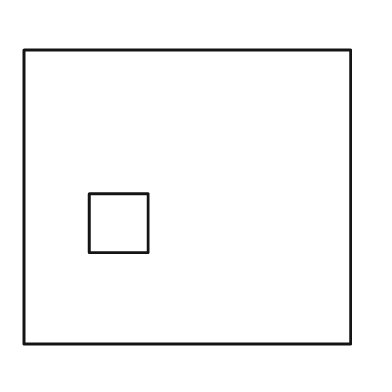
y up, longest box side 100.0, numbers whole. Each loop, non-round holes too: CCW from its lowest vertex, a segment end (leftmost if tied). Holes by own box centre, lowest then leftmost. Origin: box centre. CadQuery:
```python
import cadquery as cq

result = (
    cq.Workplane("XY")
    .moveTo(-50.0, -45.0)
    .lineTo(50.0, -45.0)
    .lineTo(50.0, 45.0)
    .lineTo(-50.0, 45.0)
    .close()
    .moveTo(-30.0, -17.0)
    .lineTo(-12.0, -17.0)
    .lineTo(-12.0, 1.0)
    .lineTo(-30.0, 1.0)
    .close()
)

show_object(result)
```